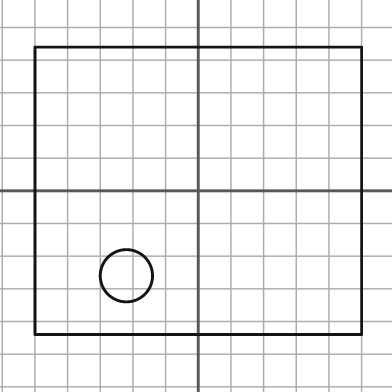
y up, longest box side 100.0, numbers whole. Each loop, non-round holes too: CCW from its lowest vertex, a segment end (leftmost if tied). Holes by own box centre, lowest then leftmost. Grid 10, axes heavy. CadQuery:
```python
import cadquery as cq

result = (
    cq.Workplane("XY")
    .moveTo(-50.0, -44.0)
    .lineTo(50.0, -44.0)
    .lineTo(50.0, 44.0)
    .lineTo(-50.0, 44.0)
    .close()
    .moveTo(-22.0, -26.0)
    .circle(8.0)
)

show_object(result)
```